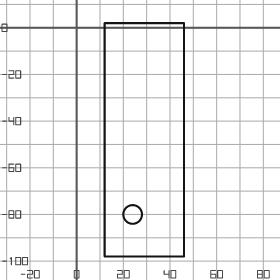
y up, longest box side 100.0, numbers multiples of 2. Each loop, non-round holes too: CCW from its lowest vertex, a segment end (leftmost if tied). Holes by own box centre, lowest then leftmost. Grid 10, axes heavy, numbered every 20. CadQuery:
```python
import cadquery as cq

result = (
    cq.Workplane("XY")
    .moveTo(12.0, -98.0)
    .lineTo(46.0, -98.0)
    .lineTo(46.0, 2.0)
    .lineTo(12.0, 2.0)
    .close()
    .moveTo(24.0, -80.0)
    .circle(4.0)
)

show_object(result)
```